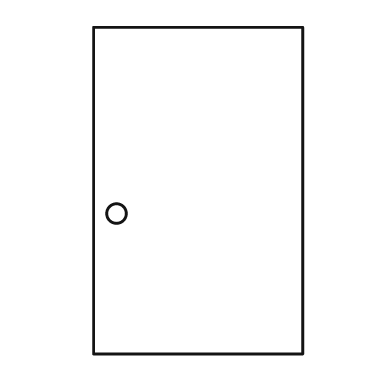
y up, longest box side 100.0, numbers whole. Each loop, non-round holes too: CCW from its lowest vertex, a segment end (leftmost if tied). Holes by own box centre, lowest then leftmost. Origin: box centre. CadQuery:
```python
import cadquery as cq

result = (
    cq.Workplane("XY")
    .moveTo(-32.0, -50.0)
    .lineTo(32.0, -50.0)
    .lineTo(32.0, 50.0)
    .lineTo(-32.0, 50.0)
    .close()
    .moveTo(-25.0, -7.0)
    .circle(3.0)
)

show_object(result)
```